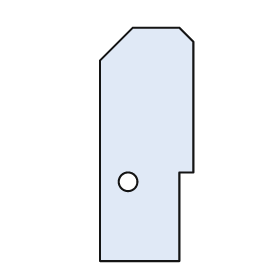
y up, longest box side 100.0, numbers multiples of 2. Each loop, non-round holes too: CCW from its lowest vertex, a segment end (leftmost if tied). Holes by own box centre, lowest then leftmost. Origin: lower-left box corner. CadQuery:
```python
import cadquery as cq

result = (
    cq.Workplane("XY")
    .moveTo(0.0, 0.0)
    .lineTo(34.0, 0.0)
    .lineTo(34.0, 38.0)
    .lineTo(40.0, 38.0)
    .lineTo(40.0, 94.0)
    .lineTo(34.0, 100.0)
    .lineTo(14.0, 100.0)
    .lineTo(0.0, 86.0)
    .close()
    .moveTo(12.0, 34.0)
    .circle(4.0)
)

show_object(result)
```